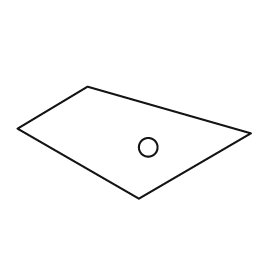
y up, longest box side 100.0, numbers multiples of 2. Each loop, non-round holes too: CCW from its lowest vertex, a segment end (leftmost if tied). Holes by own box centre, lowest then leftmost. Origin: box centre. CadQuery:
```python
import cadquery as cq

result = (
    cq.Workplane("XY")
    .moveTo(2.0, -24.0)
    .lineTo(50.0, 4.0)
    .lineTo(-20.0, 24.0)
    .lineTo(-50.0, 6.0)
    .close()
    .moveTo(6.0, -2.0)
    .circle(4.0)
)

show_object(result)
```